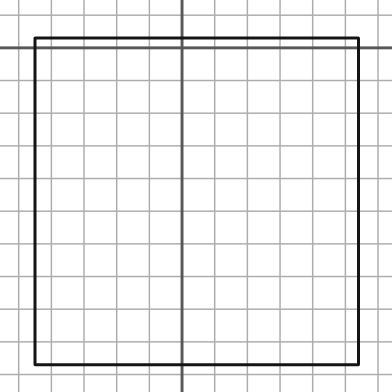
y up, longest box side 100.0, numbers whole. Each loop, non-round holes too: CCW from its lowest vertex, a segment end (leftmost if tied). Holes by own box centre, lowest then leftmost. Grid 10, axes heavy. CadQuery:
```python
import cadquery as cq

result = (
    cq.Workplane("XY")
    .moveTo(-45.0, -97.0)
    .lineTo(54.0, -97.0)
    .lineTo(54.0, 3.0)
    .lineTo(-45.0, 3.0)
    .close()
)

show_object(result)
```